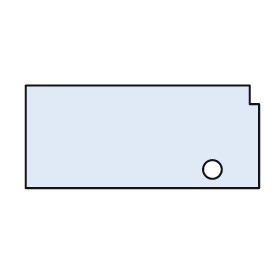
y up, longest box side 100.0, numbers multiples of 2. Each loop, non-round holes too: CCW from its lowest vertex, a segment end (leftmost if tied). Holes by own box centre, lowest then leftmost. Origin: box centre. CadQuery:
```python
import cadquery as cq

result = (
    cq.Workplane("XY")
    .moveTo(-50.0, -22.0)
    .lineTo(50.0, -22.0)
    .lineTo(50.0, 14.0)
    .lineTo(46.0, 14.0)
    .lineTo(46.0, 22.0)
    .lineTo(-50.0, 22.0)
    .close()
    .moveTo(30.0, -14.0)
    .circle(4.0)
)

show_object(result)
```